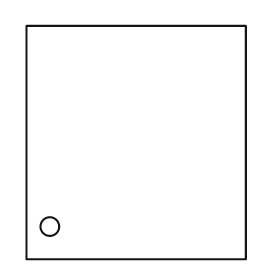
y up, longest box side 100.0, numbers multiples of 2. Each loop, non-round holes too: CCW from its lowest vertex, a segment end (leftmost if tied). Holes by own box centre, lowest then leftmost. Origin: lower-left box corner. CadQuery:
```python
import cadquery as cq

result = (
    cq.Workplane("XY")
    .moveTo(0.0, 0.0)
    .lineTo(94.0, 0.0)
    .lineTo(94.0, 100.0)
    .lineTo(0.0, 100.0)
    .close()
    .moveTo(10.0, 14.0)
    .circle(4.0)
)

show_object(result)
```